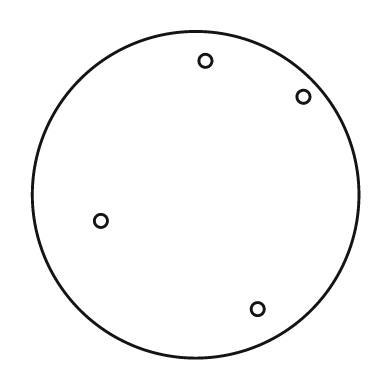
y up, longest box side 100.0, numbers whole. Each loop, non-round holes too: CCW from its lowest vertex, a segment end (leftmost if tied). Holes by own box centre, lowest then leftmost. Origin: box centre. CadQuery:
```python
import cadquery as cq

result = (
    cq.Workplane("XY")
    .moveTo(0.0, 0.0)
    .circle(50.0)
    .moveTo(19.0, -35.0)
    .circle(2.0)
    .moveTo(-29.0, -8.0)
    .circle(2.0)
    .moveTo(33.0, 30.0)
    .circle(2.0)
    .moveTo(3.0, 41.0)
    .circle(2.0)
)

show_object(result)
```